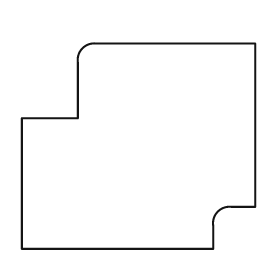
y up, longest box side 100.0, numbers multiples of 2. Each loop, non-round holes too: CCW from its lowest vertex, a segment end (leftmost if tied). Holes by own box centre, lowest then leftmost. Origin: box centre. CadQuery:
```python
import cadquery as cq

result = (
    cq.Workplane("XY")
    .moveTo(-50.0, -44.0)
    .lineTo(32.0, -44.0)
    .lineTo(32.0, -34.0)
    .threePointArc((34.0, -28.0), (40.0, -26.0))
    .lineTo(50.0, -26.0)
    .lineTo(50.0, 44.0)
    .lineTo(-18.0, 44.0)
    .threePointArc((-24.0, 42.0), (-26.0, 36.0))
    .lineTo(-26.0, 12.0)
    .lineTo(-50.0, 12.0)
    .close()
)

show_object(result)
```